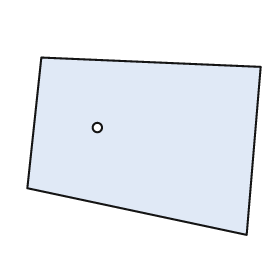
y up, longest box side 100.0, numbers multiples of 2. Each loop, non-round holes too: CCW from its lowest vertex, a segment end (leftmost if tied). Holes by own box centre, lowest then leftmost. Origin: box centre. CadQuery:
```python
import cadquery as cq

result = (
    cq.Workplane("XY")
    .moveTo(44.0, -38.0)
    .lineTo(50.0, 34.0)
    .lineTo(-44.0, 38.0)
    .lineTo(-50.0, -18.0)
    .close()
    .moveTo(-20.0, 8.0)
    .circle(2.0)
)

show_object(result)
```